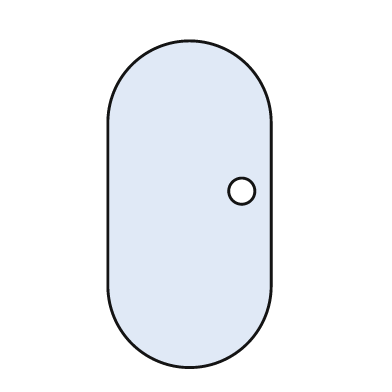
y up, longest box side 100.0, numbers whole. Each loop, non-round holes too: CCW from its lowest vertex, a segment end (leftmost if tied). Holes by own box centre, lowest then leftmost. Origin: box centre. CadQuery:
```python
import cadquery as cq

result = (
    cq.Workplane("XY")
    .moveTo(-25.0, -25.0)
    .threePointArc((0.0, -50.0), (25.0, -25.0))
    .lineTo(25.0, 25.0)
    .threePointArc((0.0, 50.0), (-25.0, 25.0))
    .close()
    .moveTo(16.0, 4.0)
    .circle(4.0)
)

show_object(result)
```